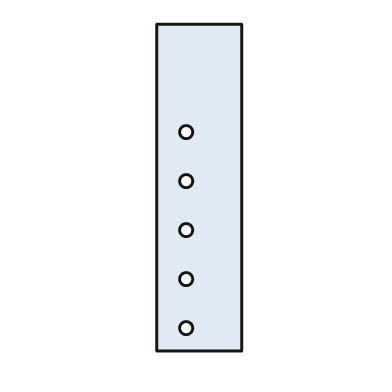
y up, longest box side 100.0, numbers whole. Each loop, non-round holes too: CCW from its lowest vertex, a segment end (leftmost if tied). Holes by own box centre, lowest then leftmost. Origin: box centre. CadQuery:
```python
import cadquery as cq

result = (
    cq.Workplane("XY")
    .moveTo(-13.0, -50.0)
    .lineTo(13.0, -50.0)
    .lineTo(13.0, 50.0)
    .lineTo(-13.0, 50.0)
    .close()
    .moveTo(-4.0, -43.0)
    .circle(2.0)
    .moveTo(-4.0, -28.0)
    .circle(2.0)
    .moveTo(-4.0, -13.0)
    .circle(2.0)
    .moveTo(-4.0, 2.0)
    .circle(2.0)
    .moveTo(-4.0, 17.0)
    .circle(2.0)
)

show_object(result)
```